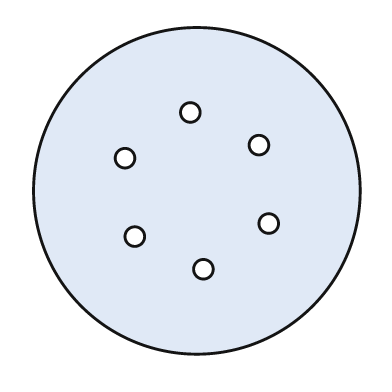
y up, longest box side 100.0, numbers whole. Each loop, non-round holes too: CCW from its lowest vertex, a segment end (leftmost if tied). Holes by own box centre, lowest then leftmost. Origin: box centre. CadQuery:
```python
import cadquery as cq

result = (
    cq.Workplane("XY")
    .moveTo(0.0, 0.0)
    .circle(50.0)
    .moveTo(2.0, -24.0)
    .circle(3.0)
    .moveTo(-19.0, -14.0)
    .circle(3.0)
    .moveTo(22.0, -10.0)
    .circle(3.0)
    .moveTo(-22.0, 10.0)
    .circle(3.0)
    .moveTo(19.0, 14.0)
    .circle(3.0)
    .moveTo(-2.0, 24.0)
    .circle(3.0)
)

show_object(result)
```